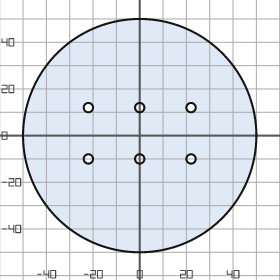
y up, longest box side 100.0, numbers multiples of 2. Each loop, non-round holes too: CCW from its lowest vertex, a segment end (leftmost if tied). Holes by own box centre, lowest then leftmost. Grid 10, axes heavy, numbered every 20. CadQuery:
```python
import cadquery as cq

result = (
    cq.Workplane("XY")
    .moveTo(0.0, 0.0)
    .circle(50.0)
    .moveTo(-22.0, -10.0)
    .circle(2.0)
    .moveTo(0.0, -10.0)
    .circle(2.0)
    .moveTo(22.0, -10.0)
    .circle(2.0)
    .moveTo(-22.0, 12.0)
    .circle(2.0)
    .moveTo(0.0, 12.0)
    .circle(2.0)
    .moveTo(22.0, 12.0)
    .circle(2.0)
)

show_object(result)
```